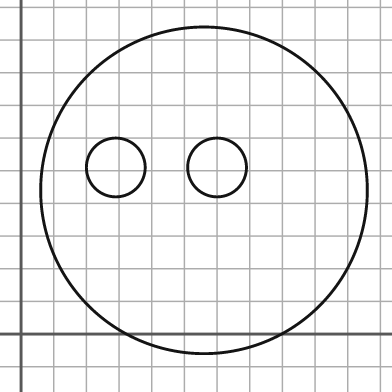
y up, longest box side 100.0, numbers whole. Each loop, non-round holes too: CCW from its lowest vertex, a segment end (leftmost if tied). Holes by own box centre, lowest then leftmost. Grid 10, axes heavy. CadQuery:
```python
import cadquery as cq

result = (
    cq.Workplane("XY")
    .moveTo(56.0, 44.0)
    .circle(50.0)
    .moveTo(29.0, 51.0)
    .circle(9.0)
    .moveTo(60.0, 51.0)
    .circle(9.0)
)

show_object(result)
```